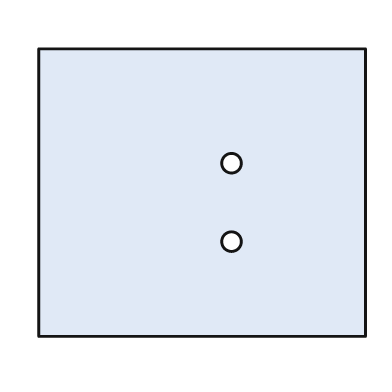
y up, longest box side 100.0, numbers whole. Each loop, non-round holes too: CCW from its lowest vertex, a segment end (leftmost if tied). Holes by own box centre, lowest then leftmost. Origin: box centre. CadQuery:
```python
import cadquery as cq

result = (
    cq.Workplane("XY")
    .moveTo(-50.0, -44.0)
    .lineTo(50.0, -44.0)
    .lineTo(50.0, 44.0)
    .lineTo(-50.0, 44.0)
    .close()
    .moveTo(9.0, -15.0)
    .circle(3.0)
    .moveTo(9.0, 9.0)
    .circle(3.0)
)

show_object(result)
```